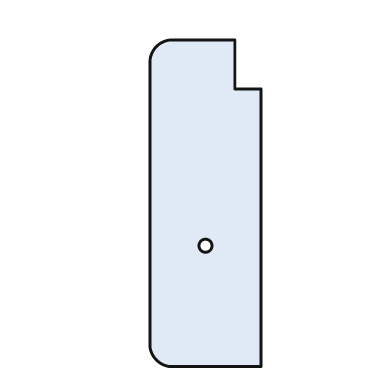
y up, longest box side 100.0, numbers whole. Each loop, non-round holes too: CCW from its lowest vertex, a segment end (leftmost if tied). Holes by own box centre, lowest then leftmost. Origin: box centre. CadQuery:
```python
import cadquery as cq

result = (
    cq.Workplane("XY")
    .moveTo(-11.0, -50.0)
    .lineTo(17.0, -50.0)
    .lineTo(17.0, 35.0)
    .lineTo(9.0, 35.0)
    .lineTo(9.0, 50.0)
    .lineTo(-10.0, 50.0)
    .threePointArc((-15.0, 48.0), (-17.0, 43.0))
    .lineTo(-17.0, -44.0)
    .threePointArc((-15.0, -48.0), (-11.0, -50.0))
    .close()
    .moveTo(0.0, -13.0)
    .circle(2.0)
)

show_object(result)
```